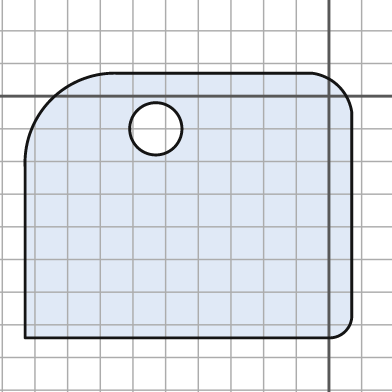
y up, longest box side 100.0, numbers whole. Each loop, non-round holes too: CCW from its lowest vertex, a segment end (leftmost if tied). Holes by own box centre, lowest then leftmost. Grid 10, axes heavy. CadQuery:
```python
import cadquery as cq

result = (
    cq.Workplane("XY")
    .moveTo(-93.0, -74.0)
    .lineTo(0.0, -74.0)
    .threePointArc((5.0, -72.0), (7.0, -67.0))
    .lineTo(7.0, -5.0)
    .threePointArc((3.0, 3.0), (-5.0, 7.0))
    .lineTo(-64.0, 7.0)
    .threePointArc((-85.0, -1.0), (-93.0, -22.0))
    .close()
    .moveTo(-53.0, -10.0)
    .circle(8.0)
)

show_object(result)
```